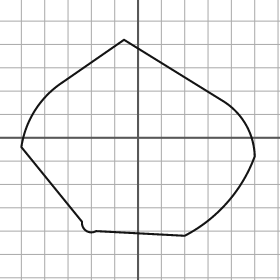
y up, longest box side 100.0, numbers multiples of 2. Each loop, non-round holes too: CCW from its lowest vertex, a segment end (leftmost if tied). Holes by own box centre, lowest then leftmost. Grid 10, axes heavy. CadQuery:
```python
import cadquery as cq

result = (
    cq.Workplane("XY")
    .moveTo(20.0, -42.0)
    .threePointArc((38.0, -28.0), (50.0, -8.0))
    .threePointArc((46.0, 6.0), (36.0, 16.0))
    .lineTo(-6.0, 42.0)
    .lineTo(-32.0, 24.0)
    .threePointArc((-44.0, 12.0), (-50.0, -4.0))
    .lineTo(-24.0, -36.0)
    .threePointArc((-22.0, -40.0), (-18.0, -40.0))
    .close()
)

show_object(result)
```